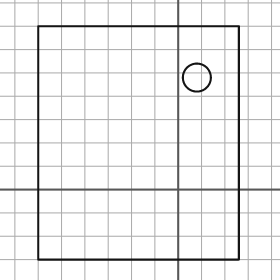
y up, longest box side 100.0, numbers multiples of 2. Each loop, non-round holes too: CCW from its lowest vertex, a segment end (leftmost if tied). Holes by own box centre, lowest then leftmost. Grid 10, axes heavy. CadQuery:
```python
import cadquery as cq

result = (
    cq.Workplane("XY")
    .moveTo(-60.0, -30.0)
    .lineTo(26.0, -30.0)
    .lineTo(26.0, 70.0)
    .lineTo(-60.0, 70.0)
    .close()
    .moveTo(8.0, 48.0)
    .circle(6.0)
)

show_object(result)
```